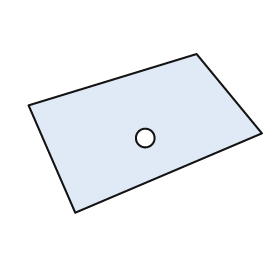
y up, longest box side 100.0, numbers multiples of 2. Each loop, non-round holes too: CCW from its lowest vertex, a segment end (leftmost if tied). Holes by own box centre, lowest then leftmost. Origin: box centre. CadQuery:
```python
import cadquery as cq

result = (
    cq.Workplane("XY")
    .moveTo(-30.0, -34.0)
    .lineTo(50.0, 0.0)
    .lineTo(22.0, 34.0)
    .lineTo(-50.0, 12.0)
    .close()
    .moveTo(0.0, -2.0)
    .circle(4.0)
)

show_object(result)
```